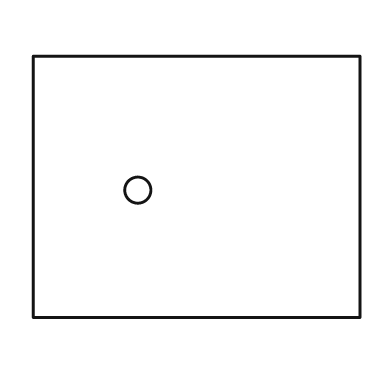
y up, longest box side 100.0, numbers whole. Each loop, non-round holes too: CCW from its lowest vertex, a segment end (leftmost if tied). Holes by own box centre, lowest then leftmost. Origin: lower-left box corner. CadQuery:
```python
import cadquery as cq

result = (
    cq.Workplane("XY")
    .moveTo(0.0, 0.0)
    .lineTo(100.0, 0.0)
    .lineTo(100.0, 80.0)
    .lineTo(0.0, 80.0)
    .close()
    .moveTo(32.0, 39.0)
    .circle(4.0)
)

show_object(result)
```